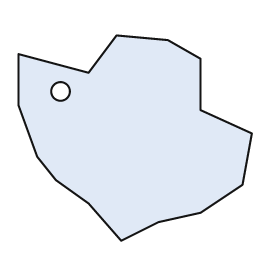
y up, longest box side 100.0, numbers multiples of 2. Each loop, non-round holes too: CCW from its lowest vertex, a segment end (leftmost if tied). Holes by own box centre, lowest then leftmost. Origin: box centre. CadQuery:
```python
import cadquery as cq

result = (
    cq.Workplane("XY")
    .moveTo(-6.0, -44.0)
    .lineTo(10.0, -36.0)
    .lineTo(28.0, -32.0)
    .lineTo(46.0, -20.0)
    .lineTo(50.0, 2.0)
    .lineTo(28.0, 12.0)
    .lineTo(28.0, 34.0)
    .lineTo(14.0, 42.0)
    .lineTo(-8.0, 44.0)
    .lineTo(-20.0, 28.0)
    .lineTo(-50.0, 36.0)
    .lineTo(-50.0, 14.0)
    .lineTo(-42.0, -8.0)
    .lineTo(-34.0, -18.0)
    .lineTo(-20.0, -28.0)
    .close()
    .moveTo(-32.0, 20.0)
    .circle(4.0)
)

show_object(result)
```